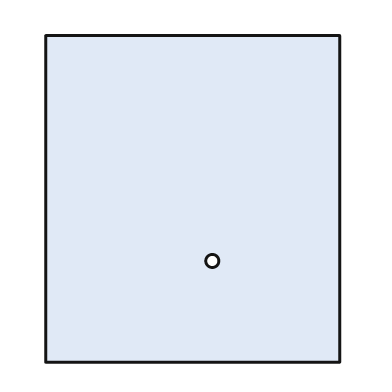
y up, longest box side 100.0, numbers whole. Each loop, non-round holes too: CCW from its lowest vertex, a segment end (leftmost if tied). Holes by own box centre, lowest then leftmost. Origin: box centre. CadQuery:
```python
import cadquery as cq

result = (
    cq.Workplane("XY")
    .moveTo(-45.0, -50.0)
    .lineTo(45.0, -50.0)
    .lineTo(45.0, 50.0)
    .lineTo(-45.0, 50.0)
    .close()
    .moveTo(6.0, -19.0)
    .circle(2.0)
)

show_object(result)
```